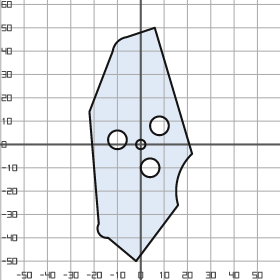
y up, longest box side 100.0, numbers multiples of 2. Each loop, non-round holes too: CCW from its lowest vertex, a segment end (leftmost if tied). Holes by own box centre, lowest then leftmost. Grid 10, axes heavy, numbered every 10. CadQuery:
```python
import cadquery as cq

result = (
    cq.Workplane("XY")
    .moveTo(-2.0, -50.0)
    .lineTo(16.0, -26.0)
    .threePointArc((16.0, -14.0), (22.0, -4.0))
    .lineTo(6.0, 50.0)
    .lineTo(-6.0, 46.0)
    .threePointArc((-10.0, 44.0), (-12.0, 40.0))
    .lineTo(-22.0, 14.0)
    .lineTo(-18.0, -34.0)
    .threePointArc((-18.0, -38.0), (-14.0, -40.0))
    .close()
    .moveTo(4.0, -10.0)
    .circle(4.0)
    .moveTo(0.0, 0.0)
    .circle(2.0)
    .moveTo(-10.0, 2.0)
    .circle(4.0)
    .moveTo(8.0, 8.0)
    .circle(4.0)
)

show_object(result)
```